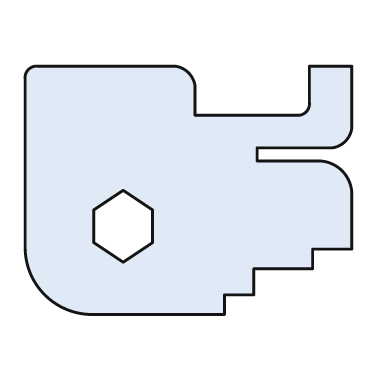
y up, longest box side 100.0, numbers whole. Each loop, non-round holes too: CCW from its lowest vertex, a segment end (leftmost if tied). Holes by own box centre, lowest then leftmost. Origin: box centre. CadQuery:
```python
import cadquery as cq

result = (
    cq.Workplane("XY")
    .moveTo(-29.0, -38.0)
    .lineTo(11.0, -38.0)
    .lineTo(11.0, -32.0)
    .lineTo(20.0, -32.0)
    .lineTo(20.0, -24.0)
    .lineTo(38.0, -24.0)
    .lineTo(38.0, -18.0)
    .lineTo(50.0, -18.0)
    .lineTo(50.0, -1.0)
    .threePointArc((47.0, 6.0), (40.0, 9.0))
    .lineTo(21.0, 9.0)
    .lineTo(21.0, 13.0)
    .lineTo(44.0, 13.0)
    .threePointArc((48.0, 15.0), (50.0, 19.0))
    .lineTo(50.0, 38.0)
    .lineTo(37.0, 38.0)
    .lineTo(37.0, 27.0)
    .threePointArc((36.0, 24.0), (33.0, 23.0))
    .lineTo(2.0, 23.0)
    .lineTo(2.0, 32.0)
    .threePointArc((0.0, 36.0), (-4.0, 38.0))
    .lineTo(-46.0, 38.0)
    .threePointArc((-49.0, 37.0), (-50.0, 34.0))
    .lineTo(-50.0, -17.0)
    .threePointArc((-44.0, -32.0), (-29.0, -38.0))
    .close()
    .moveTo(-20.0, -22.0)
    .lineTo(-11.0, -16.0)
    .lineTo(-11.0, -6.0)
    .lineTo(-20.0, 0.0)
    .lineTo(-29.0, -6.0)
    .lineTo(-29.0, -16.0)
    .close()
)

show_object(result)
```